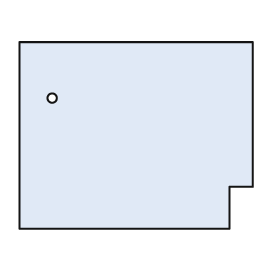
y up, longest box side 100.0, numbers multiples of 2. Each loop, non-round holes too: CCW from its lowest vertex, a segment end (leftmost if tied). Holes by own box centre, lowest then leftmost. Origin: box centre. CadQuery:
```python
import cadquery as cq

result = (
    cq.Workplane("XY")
    .moveTo(-50.0, -40.0)
    .lineTo(40.0, -40.0)
    .lineTo(40.0, -22.0)
    .lineTo(50.0, -22.0)
    .lineTo(50.0, 40.0)
    .lineTo(-50.0, 40.0)
    .close()
    .moveTo(-36.0, 16.0)
    .circle(2.0)
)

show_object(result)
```